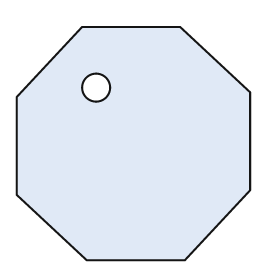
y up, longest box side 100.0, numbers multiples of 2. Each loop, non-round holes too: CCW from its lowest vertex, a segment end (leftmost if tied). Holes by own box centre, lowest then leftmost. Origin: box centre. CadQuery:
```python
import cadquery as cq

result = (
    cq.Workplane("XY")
    .moveTo(-20.0, -50.0)
    .lineTo(22.0, -50.0)
    .lineTo(50.0, -20.0)
    .lineTo(50.0, 22.0)
    .lineTo(20.0, 50.0)
    .lineTo(-22.0, 50.0)
    .lineTo(-50.0, 20.0)
    .lineTo(-50.0, -22.0)
    .close()
    .moveTo(-16.0, 24.0)
    .circle(6.0)
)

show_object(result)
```